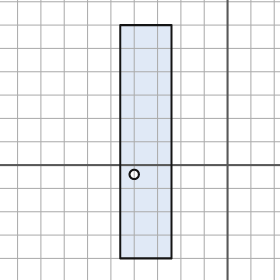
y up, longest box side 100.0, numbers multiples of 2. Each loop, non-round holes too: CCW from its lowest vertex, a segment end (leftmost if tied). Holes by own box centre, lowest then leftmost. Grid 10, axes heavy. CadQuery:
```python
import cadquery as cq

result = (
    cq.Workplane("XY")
    .moveTo(-46.0, -40.0)
    .lineTo(-24.0, -40.0)
    .lineTo(-24.0, 60.0)
    .lineTo(-46.0, 60.0)
    .close()
    .moveTo(-40.0, -4.0)
    .circle(2.0)
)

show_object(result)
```